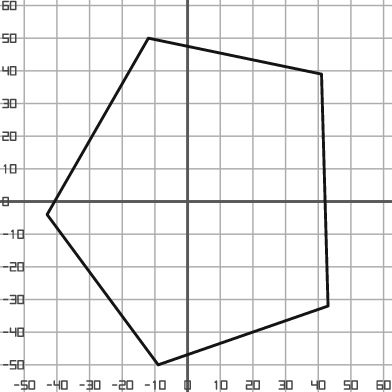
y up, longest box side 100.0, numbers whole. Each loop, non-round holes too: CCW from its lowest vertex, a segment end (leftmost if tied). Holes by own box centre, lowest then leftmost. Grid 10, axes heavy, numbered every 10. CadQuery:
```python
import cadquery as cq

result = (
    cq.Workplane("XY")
    .moveTo(-9.0, -50.0)
    .lineTo(43.0, -32.0)
    .lineTo(41.0, 39.0)
    .lineTo(-12.0, 50.0)
    .lineTo(-43.0, -4.0)
    .close()
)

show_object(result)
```